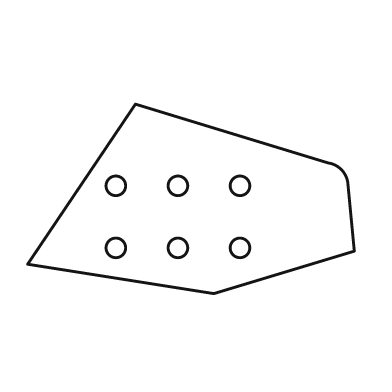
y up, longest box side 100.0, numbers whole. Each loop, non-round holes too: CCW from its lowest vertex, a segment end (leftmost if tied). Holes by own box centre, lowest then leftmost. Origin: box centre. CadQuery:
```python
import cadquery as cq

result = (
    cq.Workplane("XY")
    .moveTo(7.0, -29.0)
    .lineTo(50.0, -16.0)
    .lineTo(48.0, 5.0)
    .threePointArc((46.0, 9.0), (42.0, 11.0))
    .lineTo(-17.0, 29.0)
    .lineTo(-50.0, -20.0)
    .close()
    .moveTo(-23.0, -15.0)
    .circle(3.0)
    .moveTo(-4.0, -15.0)
    .circle(3.0)
    .moveTo(15.0, -15.0)
    .circle(3.0)
    .moveTo(-23.0, 4.0)
    .circle(3.0)
    .moveTo(-4.0, 4.0)
    .circle(3.0)
    .moveTo(15.0, 4.0)
    .circle(3.0)
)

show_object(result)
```